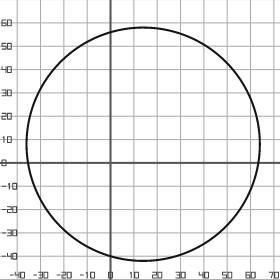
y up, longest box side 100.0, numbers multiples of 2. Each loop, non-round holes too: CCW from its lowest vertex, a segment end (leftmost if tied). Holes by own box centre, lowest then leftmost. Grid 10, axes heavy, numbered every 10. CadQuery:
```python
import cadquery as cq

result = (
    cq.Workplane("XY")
    .moveTo(14.0, 8.0)
    .circle(50.0)
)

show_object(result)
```